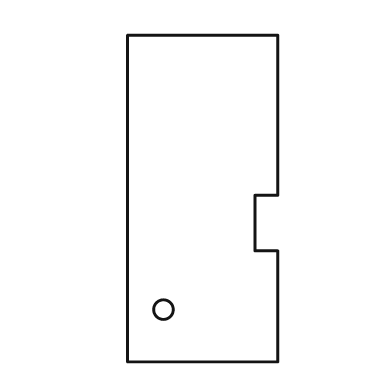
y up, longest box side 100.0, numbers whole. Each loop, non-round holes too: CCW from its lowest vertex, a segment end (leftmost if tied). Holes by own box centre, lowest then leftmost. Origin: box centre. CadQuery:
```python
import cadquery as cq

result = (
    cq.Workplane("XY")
    .moveTo(-23.0, -50.0)
    .lineTo(23.0, -50.0)
    .lineTo(23.0, -16.0)
    .lineTo(16.0, -16.0)
    .lineTo(16.0, 1.0)
    .lineTo(23.0, 1.0)
    .lineTo(23.0, 50.0)
    .lineTo(-23.0, 50.0)
    .close()
    .moveTo(-12.0, -34.0)
    .circle(3.0)
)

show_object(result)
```